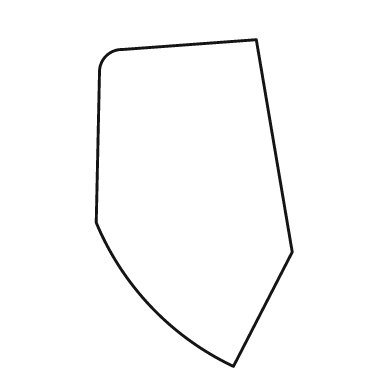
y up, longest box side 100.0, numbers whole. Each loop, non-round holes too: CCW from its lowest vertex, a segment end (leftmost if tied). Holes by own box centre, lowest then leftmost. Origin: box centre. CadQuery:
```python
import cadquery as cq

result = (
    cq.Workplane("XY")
    .moveTo(12.0, -50.0)
    .lineTo(30.0, -15.0)
    .lineTo(19.0, 50.0)
    .lineTo(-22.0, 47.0)
    .threePointArc((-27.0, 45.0), (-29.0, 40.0))
    .lineTo(-30.0, -6.0)
    .threePointArc((-13.0, -32.0), (12.0, -50.0))
    .close()
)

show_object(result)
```